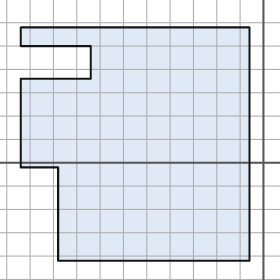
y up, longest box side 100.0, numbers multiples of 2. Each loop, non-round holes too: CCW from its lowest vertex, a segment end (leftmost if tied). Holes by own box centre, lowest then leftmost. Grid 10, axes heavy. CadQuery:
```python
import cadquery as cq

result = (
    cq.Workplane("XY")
    .moveTo(-88.0, -42.0)
    .lineTo(-6.0, -42.0)
    .lineTo(-6.0, 58.0)
    .lineTo(-104.0, 58.0)
    .lineTo(-104.0, 50.0)
    .lineTo(-74.0, 50.0)
    .lineTo(-74.0, 36.0)
    .lineTo(-104.0, 36.0)
    .lineTo(-104.0, -2.0)
    .lineTo(-88.0, -2.0)
    .close()
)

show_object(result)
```